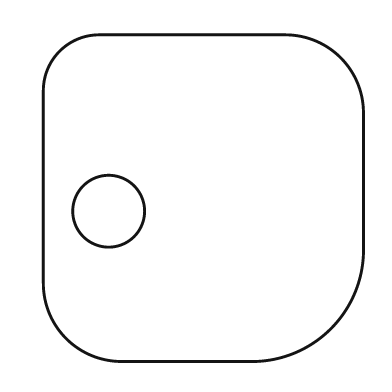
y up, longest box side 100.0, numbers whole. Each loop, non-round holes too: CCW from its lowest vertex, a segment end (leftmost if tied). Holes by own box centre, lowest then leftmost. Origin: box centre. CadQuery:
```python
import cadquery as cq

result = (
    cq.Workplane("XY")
    .moveTo(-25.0, -50.0)
    .lineTo(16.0, -50.0)
    .threePointArc((39.0, -40.0), (49.0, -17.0))
    .lineTo(49.0, 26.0)
    .threePointArc((42.0, 43.0), (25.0, 50.0))
    .lineTo(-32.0, 50.0)
    .threePointArc((-44.0, 45.0), (-49.0, 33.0))
    .lineTo(-49.0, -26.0)
    .threePointArc((-42.0, -43.0), (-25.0, -50.0))
    .close()
    .moveTo(-29.0, -4.0)
    .circle(11.0)
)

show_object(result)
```